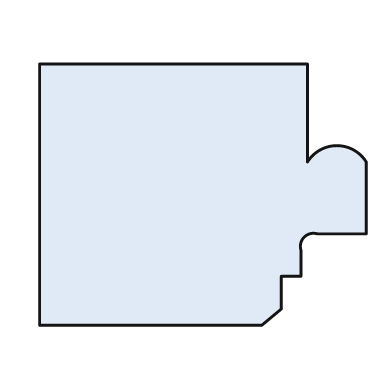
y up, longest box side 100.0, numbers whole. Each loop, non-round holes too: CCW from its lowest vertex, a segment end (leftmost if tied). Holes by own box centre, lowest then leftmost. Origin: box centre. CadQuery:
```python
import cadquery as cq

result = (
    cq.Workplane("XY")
    .moveTo(-50.0, -40.0)
    .lineTo(18.0, -40.0)
    .lineTo(24.0, -35.0)
    .lineTo(24.0, -25.0)
    .lineTo(30.0, -25.0)
    .lineTo(30.0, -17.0)
    .threePointArc((31.0, -13.0), (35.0, -12.0))
    .lineTo(50.0, -12.0)
    .lineTo(50.0, 10.0)
    .threePointArc((41.0, 15.0), (32.0, 10.0))
    .lineTo(32.0, 40.0)
    .lineTo(-50.0, 40.0)
    .close()
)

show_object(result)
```